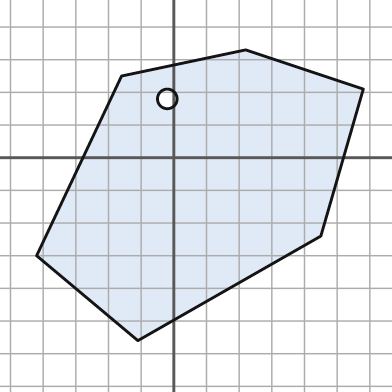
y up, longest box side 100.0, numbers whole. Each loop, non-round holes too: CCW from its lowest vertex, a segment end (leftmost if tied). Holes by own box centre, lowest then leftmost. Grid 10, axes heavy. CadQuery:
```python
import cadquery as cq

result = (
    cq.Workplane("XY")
    .moveTo(-11.0, -56.0)
    .lineTo(45.0, -24.0)
    .lineTo(58.0, 21.0)
    .lineTo(22.0, 33.0)
    .lineTo(-16.0, 25.0)
    .lineTo(-42.0, -30.0)
    .close()
    .moveTo(-2.0, 18.0)
    .circle(3.0)
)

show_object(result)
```